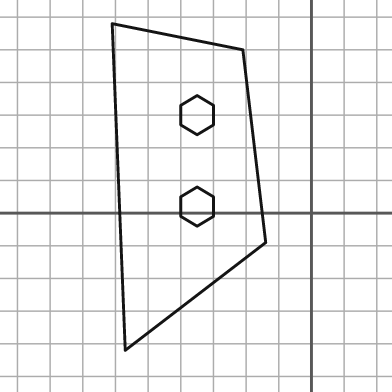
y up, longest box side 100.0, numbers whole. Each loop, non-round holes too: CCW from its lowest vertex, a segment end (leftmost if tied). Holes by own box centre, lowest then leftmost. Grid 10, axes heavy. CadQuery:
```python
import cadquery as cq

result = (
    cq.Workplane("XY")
    .moveTo(-57.0, -42.0)
    .lineTo(-14.0, -9.0)
    .lineTo(-21.0, 50.0)
    .lineTo(-61.0, 58.0)
    .close()
    .moveTo(-35.0, -4.0)
    .lineTo(-30.0, -1.0)
    .lineTo(-30.0, 5.0)
    .lineTo(-35.0, 8.0)
    .lineTo(-40.0, 5.0)
    .lineTo(-40.0, -1.0)
    .close()
    .moveTo(-35.0, 24.0)
    .lineTo(-30.0, 27.0)
    .lineTo(-30.0, 33.0)
    .lineTo(-35.0, 36.0)
    .lineTo(-40.0, 33.0)
    .lineTo(-40.0, 27.0)
    .close()
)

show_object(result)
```